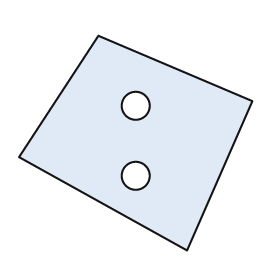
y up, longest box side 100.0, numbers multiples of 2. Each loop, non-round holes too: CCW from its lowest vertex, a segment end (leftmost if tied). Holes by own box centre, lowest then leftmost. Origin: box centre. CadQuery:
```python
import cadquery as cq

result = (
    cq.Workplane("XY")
    .moveTo(22.0, -46.0)
    .lineTo(50.0, 18.0)
    .lineTo(-16.0, 46.0)
    .lineTo(-50.0, -6.0)
    .close()
    .moveTo(0.0, -14.0)
    .circle(6.0)
    .moveTo(0.0, 16.0)
    .circle(6.0)
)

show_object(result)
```